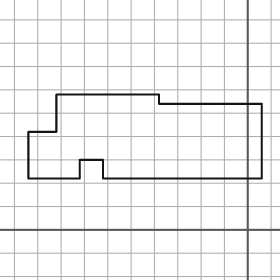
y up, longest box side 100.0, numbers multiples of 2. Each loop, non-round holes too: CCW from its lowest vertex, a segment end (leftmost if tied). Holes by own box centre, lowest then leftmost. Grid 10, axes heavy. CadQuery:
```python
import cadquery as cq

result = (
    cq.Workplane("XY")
    .moveTo(-94.0, 22.0)
    .lineTo(-72.0, 22.0)
    .lineTo(-72.0, 30.0)
    .lineTo(-62.0, 30.0)
    .lineTo(-62.0, 22.0)
    .lineTo(6.0, 22.0)
    .lineTo(6.0, 54.0)
    .lineTo(-38.0, 54.0)
    .lineTo(-38.0, 58.0)
    .lineTo(-82.0, 58.0)
    .lineTo(-82.0, 42.0)
    .lineTo(-94.0, 42.0)
    .close()
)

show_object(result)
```